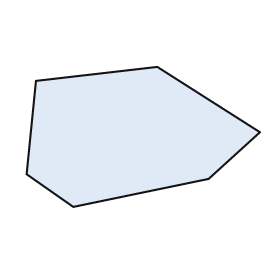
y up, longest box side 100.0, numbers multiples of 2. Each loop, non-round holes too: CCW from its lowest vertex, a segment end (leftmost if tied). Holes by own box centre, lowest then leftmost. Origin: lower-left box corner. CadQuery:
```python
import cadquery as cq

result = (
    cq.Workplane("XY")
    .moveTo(20.0, 0.0)
    .lineTo(78.0, 12.0)
    .lineTo(100.0, 32.0)
    .lineTo(56.0, 60.0)
    .lineTo(4.0, 54.0)
    .lineTo(0.0, 14.0)
    .close()
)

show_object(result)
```